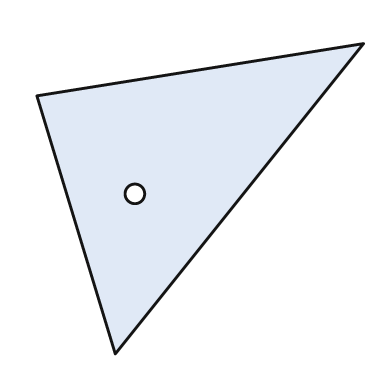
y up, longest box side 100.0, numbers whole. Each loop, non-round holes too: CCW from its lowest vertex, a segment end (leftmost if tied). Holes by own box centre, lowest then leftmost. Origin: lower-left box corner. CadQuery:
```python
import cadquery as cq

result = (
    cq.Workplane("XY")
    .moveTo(24.0, 0.0)
    .lineTo(100.0, 95.0)
    .lineTo(0.0, 79.0)
    .close()
    .moveTo(30.0, 49.0)
    .circle(3.0)
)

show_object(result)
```